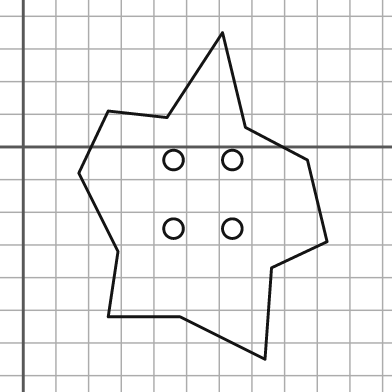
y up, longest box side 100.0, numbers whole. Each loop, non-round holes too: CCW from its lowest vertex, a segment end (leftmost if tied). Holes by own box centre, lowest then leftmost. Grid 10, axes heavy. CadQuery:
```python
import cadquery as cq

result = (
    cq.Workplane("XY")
    .moveTo(74.0, -65.0)
    .lineTo(76.0, -37.0)
    .lineTo(93.0, -29.0)
    .lineTo(87.0, -4.0)
    .lineTo(68.0, 6.0)
    .lineTo(61.0, 35.0)
    .lineTo(44.0, 9.0)
    .lineTo(26.0, 11.0)
    .lineTo(17.0, -8.0)
    .lineTo(29.0, -32.0)
    .lineTo(26.0, -52.0)
    .lineTo(48.0, -52.0)
    .close()
    .moveTo(46.0, -25.0)
    .circle(3.0)
    .moveTo(64.0, -25.0)
    .circle(3.0)
    .moveTo(46.0, -4.0)
    .circle(3.0)
    .moveTo(64.0, -4.0)
    .circle(3.0)
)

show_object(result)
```